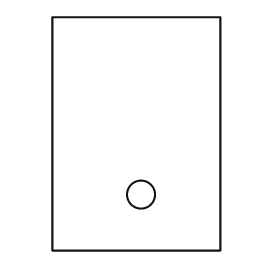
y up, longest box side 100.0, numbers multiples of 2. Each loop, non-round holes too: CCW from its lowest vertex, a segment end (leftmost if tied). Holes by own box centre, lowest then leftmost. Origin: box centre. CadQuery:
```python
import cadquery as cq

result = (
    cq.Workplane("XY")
    .moveTo(-36.0, -50.0)
    .lineTo(36.0, -50.0)
    .lineTo(36.0, 50.0)
    .lineTo(-36.0, 50.0)
    .close()
    .moveTo(2.0, -26.0)
    .circle(6.0)
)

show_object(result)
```